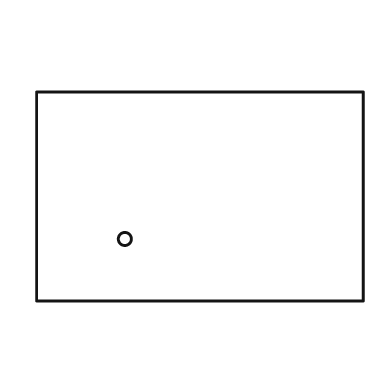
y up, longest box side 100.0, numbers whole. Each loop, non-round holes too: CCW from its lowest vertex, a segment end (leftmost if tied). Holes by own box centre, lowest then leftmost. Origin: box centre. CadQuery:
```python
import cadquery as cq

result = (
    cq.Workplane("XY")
    .moveTo(-50.0, -32.0)
    .lineTo(50.0, -32.0)
    .lineTo(50.0, 32.0)
    .lineTo(-50.0, 32.0)
    .close()
    .moveTo(-23.0, -13.0)
    .circle(2.0)
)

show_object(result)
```